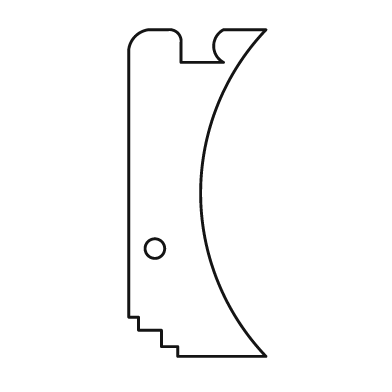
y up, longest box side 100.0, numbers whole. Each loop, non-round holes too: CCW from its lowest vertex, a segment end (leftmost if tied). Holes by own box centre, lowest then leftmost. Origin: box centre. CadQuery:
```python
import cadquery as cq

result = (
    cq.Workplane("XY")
    .moveTo(-6.0, -50.0)
    .lineTo(21.0, -50.0)
    .threePointArc((1.0, 0.0), (21.0, 50.0))
    .lineTo(8.0, 50.0)
    .threePointArc((5.0, 45.0), (8.0, 40.0))
    .lineTo(-5.0, 40.0)
    .lineTo(-5.0, 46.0)
    .threePointArc((-6.0, 49.0), (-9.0, 50.0))
    .lineTo(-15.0, 50.0)
    .threePointArc((-19.0, 48.0), (-21.0, 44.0))
    .lineTo(-21.0, -38.0)
    .lineTo(-18.0, -38.0)
    .lineTo(-18.0, -42.0)
    .lineTo(-11.0, -42.0)
    .lineTo(-11.0, -47.0)
    .lineTo(-6.0, -47.0)
    .close()
    .moveTo(-13.0, -17.0)
    .circle(3.0)
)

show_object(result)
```